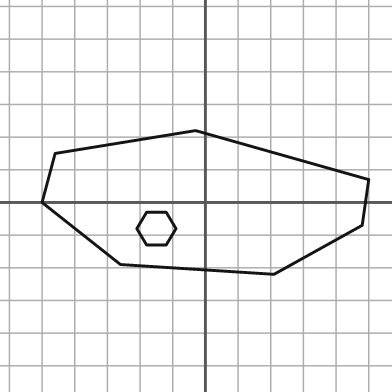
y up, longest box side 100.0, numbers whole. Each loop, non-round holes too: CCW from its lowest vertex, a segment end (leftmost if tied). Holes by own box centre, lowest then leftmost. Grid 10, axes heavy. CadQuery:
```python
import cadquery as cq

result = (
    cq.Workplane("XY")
    .moveTo(21.0, -22.0)
    .lineTo(48.0, -7.0)
    .lineTo(50.0, 7.0)
    .lineTo(-3.0, 22.0)
    .lineTo(-46.0, 15.0)
    .lineTo(-50.0, 0.0)
    .lineTo(-26.0, -19.0)
    .close()
    .moveTo(-18.0, -13.0)
    .lineTo(-12.0, -13.0)
    .lineTo(-9.0, -8.0)
    .lineTo(-12.0, -3.0)
    .lineTo(-18.0, -3.0)
    .lineTo(-21.0, -8.0)
    .close()
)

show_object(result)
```